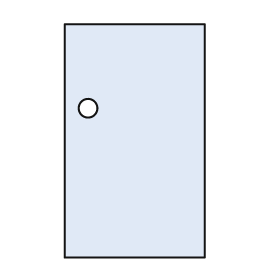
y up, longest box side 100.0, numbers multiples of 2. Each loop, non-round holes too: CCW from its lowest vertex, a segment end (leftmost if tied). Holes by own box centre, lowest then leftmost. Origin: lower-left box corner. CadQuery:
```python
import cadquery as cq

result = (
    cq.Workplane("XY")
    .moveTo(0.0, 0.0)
    .lineTo(60.0, 0.0)
    .lineTo(60.0, 100.0)
    .lineTo(0.0, 100.0)
    .close()
    .moveTo(10.0, 64.0)
    .circle(4.0)
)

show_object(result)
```